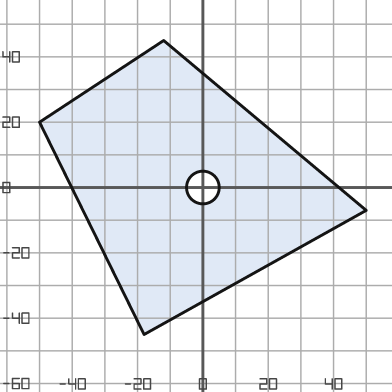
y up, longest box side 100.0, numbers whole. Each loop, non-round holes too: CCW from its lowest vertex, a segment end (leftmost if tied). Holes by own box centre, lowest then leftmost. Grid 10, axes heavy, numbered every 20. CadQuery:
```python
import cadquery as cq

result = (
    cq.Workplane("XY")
    .moveTo(-18.0, -45.0)
    .lineTo(50.0, -7.0)
    .lineTo(-12.0, 45.0)
    .lineTo(-50.0, 20.0)
    .close()
    .moveTo(0.0, 0.0)
    .circle(5.0)
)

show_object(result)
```